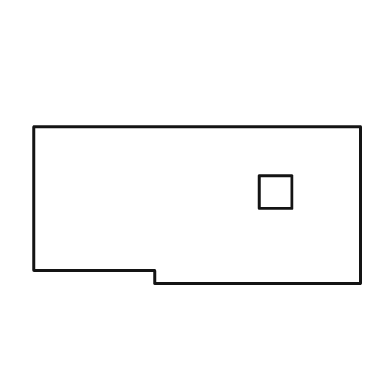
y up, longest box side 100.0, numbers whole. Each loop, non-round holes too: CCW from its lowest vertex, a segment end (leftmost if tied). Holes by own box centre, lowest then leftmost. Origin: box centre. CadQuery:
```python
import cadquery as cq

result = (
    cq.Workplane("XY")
    .moveTo(-13.0, -24.0)
    .lineTo(50.0, -24.0)
    .lineTo(50.0, 24.0)
    .lineTo(-50.0, 24.0)
    .lineTo(-50.0, -20.0)
    .lineTo(-13.0, -20.0)
    .close()
    .moveTo(19.0, -1.0)
    .lineTo(29.0, -1.0)
    .lineTo(29.0, 9.0)
    .lineTo(19.0, 9.0)
    .close()
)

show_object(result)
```